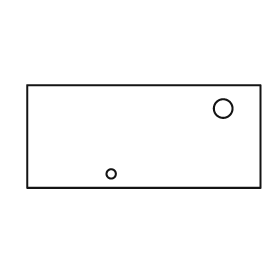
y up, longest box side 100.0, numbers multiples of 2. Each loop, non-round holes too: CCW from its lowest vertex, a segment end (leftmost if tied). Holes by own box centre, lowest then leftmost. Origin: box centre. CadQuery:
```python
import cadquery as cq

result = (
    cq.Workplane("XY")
    .moveTo(-50.0, -22.0)
    .lineTo(50.0, -22.0)
    .lineTo(50.0, 22.0)
    .lineTo(-50.0, 22.0)
    .close()
    .moveTo(-14.0, -16.0)
    .circle(2.0)
    .moveTo(34.0, 12.0)
    .circle(4.0)
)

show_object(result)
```